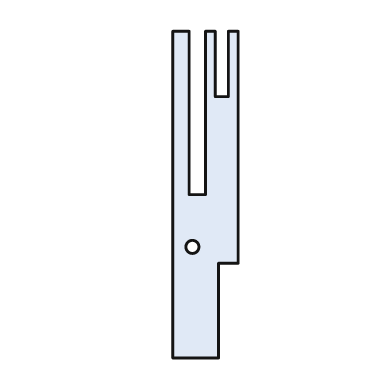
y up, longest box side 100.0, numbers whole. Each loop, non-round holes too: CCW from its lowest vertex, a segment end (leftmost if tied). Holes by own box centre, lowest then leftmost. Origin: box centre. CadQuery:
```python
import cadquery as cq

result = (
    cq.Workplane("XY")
    .moveTo(-10.0, -50.0)
    .lineTo(4.0, -50.0)
    .lineTo(4.0, -21.0)
    .lineTo(10.0, -21.0)
    .lineTo(10.0, 50.0)
    .lineTo(7.0, 50.0)
    .lineTo(7.0, 30.0)
    .lineTo(3.0, 30.0)
    .lineTo(3.0, 50.0)
    .lineTo(0.0, 50.0)
    .lineTo(0.0, 0.0)
    .lineTo(-5.0, 0.0)
    .lineTo(-5.0, 50.0)
    .lineTo(-10.0, 50.0)
    .close()
    .moveTo(-4.0, -16.0)
    .circle(2.0)
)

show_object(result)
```